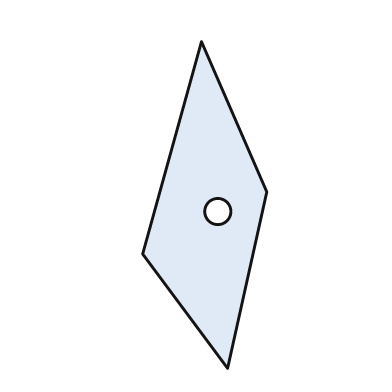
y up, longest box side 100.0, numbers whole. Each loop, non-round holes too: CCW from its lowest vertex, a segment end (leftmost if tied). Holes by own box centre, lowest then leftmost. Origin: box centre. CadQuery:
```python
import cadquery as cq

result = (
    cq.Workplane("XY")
    .moveTo(7.0, -50.0)
    .lineTo(19.0, 4.0)
    .lineTo(-1.0, 50.0)
    .lineTo(-19.0, -15.0)
    .close()
    .moveTo(4.0, -2.0)
    .circle(4.0)
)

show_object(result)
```